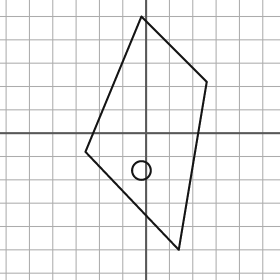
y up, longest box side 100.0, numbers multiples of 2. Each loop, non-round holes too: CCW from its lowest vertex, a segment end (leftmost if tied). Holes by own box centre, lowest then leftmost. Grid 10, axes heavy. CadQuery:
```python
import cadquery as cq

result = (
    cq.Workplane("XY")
    .moveTo(14.0, -50.0)
    .lineTo(26.0, 22.0)
    .lineTo(-2.0, 50.0)
    .lineTo(-26.0, -8.0)
    .close()
    .moveTo(-2.0, -16.0)
    .circle(4.0)
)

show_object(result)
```